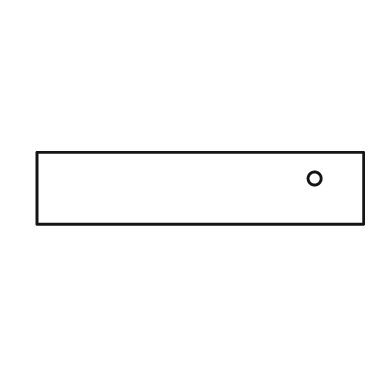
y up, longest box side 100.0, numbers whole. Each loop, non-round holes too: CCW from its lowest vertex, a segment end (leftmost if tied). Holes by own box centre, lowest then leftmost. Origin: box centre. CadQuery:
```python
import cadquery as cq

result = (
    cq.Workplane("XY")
    .moveTo(-50.0, -11.0)
    .lineTo(50.0, -11.0)
    .lineTo(50.0, 11.0)
    .lineTo(-50.0, 11.0)
    .close()
    .moveTo(35.0, 3.0)
    .circle(2.0)
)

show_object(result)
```